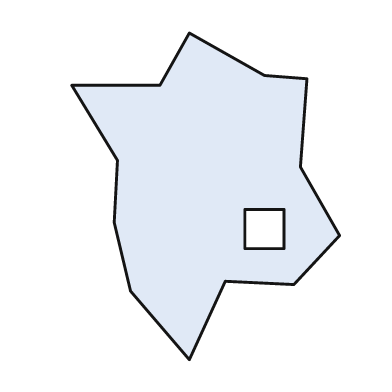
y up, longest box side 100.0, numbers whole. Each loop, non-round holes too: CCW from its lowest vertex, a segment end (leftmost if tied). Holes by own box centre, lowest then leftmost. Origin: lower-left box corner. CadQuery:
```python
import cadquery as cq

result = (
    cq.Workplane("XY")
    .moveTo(36.0, 0.0)
    .lineTo(47.0, 24.0)
    .lineTo(68.0, 23.0)
    .lineTo(82.0, 38.0)
    .lineTo(70.0, 59.0)
    .lineTo(72.0, 86.0)
    .lineTo(59.0, 87.0)
    .lineTo(36.0, 100.0)
    .lineTo(27.0, 84.0)
    .lineTo(0.0, 84.0)
    .lineTo(14.0, 61.0)
    .lineTo(13.0, 42.0)
    .lineTo(18.0, 21.0)
    .close()
    .moveTo(53.0, 34.0)
    .lineTo(65.0, 34.0)
    .lineTo(65.0, 46.0)
    .lineTo(53.0, 46.0)
    .close()
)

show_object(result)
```